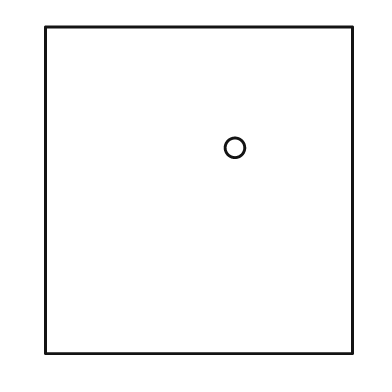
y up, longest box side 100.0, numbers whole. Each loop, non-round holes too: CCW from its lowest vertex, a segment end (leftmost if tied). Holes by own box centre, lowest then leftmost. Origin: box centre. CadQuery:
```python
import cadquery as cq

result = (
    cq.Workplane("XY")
    .moveTo(-47.0, -50.0)
    .lineTo(47.0, -50.0)
    .lineTo(47.0, 50.0)
    .lineTo(-47.0, 50.0)
    .close()
    .moveTo(11.0, 13.0)
    .circle(3.0)
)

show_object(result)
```